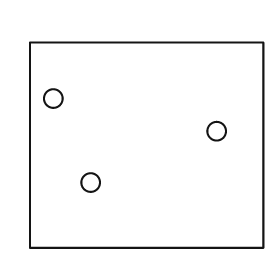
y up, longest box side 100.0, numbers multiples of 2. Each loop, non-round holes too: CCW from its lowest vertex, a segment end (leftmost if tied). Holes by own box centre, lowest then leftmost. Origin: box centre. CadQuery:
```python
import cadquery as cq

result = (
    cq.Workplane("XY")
    .moveTo(-50.0, -44.0)
    .lineTo(50.0, -44.0)
    .lineTo(50.0, 44.0)
    .lineTo(-50.0, 44.0)
    .close()
    .moveTo(-24.0, -16.0)
    .circle(4.0)
    .moveTo(30.0, 6.0)
    .circle(4.0)
    .moveTo(-40.0, 20.0)
    .circle(4.0)
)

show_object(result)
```